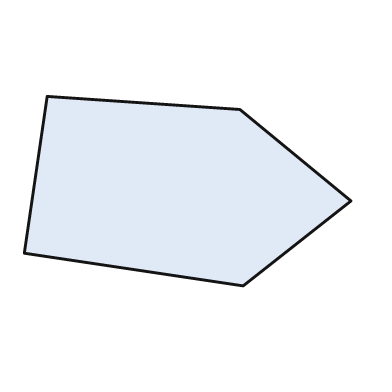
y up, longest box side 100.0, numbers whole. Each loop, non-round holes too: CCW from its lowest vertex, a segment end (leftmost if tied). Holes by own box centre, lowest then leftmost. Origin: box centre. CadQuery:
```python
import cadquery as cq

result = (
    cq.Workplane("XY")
    .moveTo(17.0, -29.0)
    .lineTo(50.0, -3.0)
    .lineTo(16.0, 25.0)
    .lineTo(-43.0, 29.0)
    .lineTo(-50.0, -19.0)
    .close()
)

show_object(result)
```